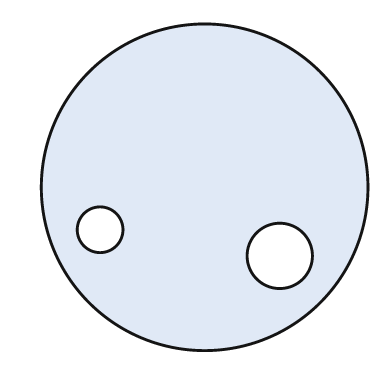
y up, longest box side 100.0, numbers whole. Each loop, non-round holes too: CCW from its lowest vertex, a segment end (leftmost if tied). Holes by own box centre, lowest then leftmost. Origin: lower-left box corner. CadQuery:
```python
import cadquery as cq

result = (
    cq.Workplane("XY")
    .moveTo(50.0, 50.0)
    .circle(50.0)
    .moveTo(73.0, 29.0)
    .circle(10.0)
    .moveTo(18.0, 37.0)
    .circle(7.0)
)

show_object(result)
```